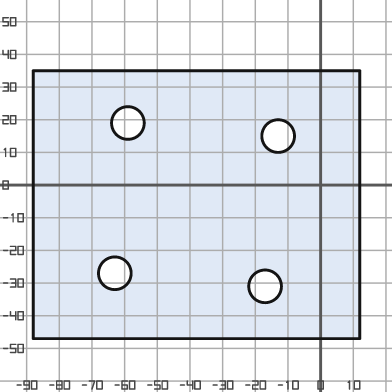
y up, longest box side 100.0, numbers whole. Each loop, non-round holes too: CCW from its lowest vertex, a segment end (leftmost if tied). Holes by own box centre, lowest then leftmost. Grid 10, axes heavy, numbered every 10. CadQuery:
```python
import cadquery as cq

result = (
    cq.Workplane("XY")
    .moveTo(-88.0, -47.0)
    .lineTo(12.0, -47.0)
    .lineTo(12.0, 35.0)
    .lineTo(-88.0, 35.0)
    .close()
    .moveTo(-17.0, -31.0)
    .circle(5.0)
    .moveTo(-63.0, -27.0)
    .circle(5.0)
    .moveTo(-13.0, 15.0)
    .circle(5.0)
    .moveTo(-59.0, 19.0)
    .circle(5.0)
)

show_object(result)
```